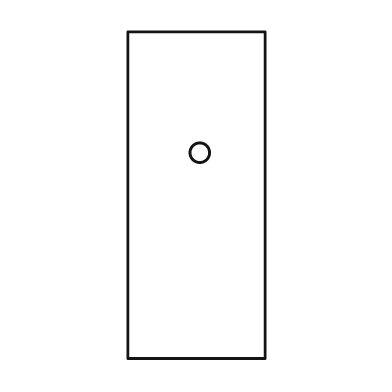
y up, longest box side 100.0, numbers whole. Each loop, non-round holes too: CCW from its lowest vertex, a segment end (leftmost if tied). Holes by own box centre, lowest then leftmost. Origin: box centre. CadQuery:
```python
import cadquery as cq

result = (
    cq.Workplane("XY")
    .moveTo(-21.0, -50.0)
    .lineTo(21.0, -50.0)
    .lineTo(21.0, 50.0)
    .lineTo(-21.0, 50.0)
    .close()
    .moveTo(1.0, 13.0)
    .circle(3.0)
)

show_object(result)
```